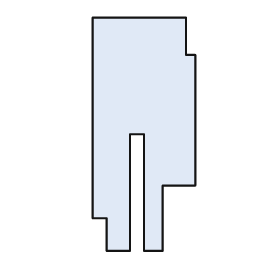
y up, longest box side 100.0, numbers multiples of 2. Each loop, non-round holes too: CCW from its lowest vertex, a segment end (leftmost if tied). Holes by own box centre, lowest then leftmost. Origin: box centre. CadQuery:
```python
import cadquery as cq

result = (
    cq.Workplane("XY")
    .moveTo(-16.0, -50.0)
    .lineTo(-6.0, -50.0)
    .lineTo(-6.0, 0.0)
    .lineTo(0.0, 0.0)
    .lineTo(0.0, -50.0)
    .lineTo(8.0, -50.0)
    .lineTo(8.0, -22.0)
    .lineTo(22.0, -22.0)
    .lineTo(22.0, 34.0)
    .lineTo(18.0, 34.0)
    .lineTo(18.0, 50.0)
    .lineTo(-22.0, 50.0)
    .lineTo(-22.0, -36.0)
    .lineTo(-16.0, -36.0)
    .close()
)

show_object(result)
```